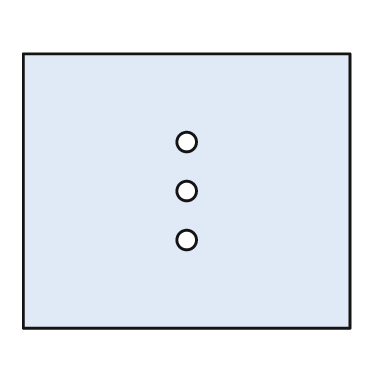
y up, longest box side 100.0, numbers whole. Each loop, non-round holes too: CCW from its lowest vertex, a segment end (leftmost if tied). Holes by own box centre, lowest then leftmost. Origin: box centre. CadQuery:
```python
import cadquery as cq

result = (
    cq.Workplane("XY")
    .moveTo(-50.0, -42.0)
    .lineTo(50.0, -42.0)
    .lineTo(50.0, 42.0)
    .lineTo(-50.0, 42.0)
    .close()
    .moveTo(0.0, -15.0)
    .circle(3.0)
    .moveTo(0.0, 0.0)
    .circle(3.0)
    .moveTo(0.0, 15.0)
    .circle(3.0)
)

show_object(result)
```